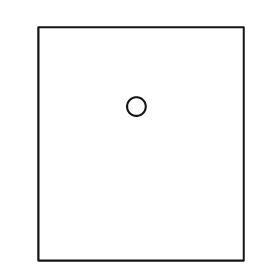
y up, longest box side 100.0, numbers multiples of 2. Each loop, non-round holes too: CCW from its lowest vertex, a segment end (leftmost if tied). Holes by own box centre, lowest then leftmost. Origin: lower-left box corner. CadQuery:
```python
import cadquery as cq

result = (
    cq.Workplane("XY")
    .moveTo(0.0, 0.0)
    .lineTo(88.0, 0.0)
    .lineTo(88.0, 100.0)
    .lineTo(0.0, 100.0)
    .close()
    .moveTo(42.0, 66.0)
    .circle(4.0)
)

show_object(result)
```